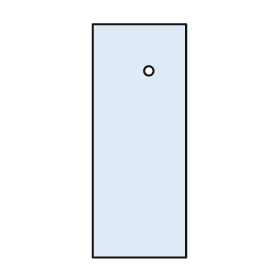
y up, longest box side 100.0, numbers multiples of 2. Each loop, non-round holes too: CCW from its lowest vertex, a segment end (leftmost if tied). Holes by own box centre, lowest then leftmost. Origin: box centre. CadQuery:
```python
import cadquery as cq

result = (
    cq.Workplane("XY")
    .moveTo(-20.0, -50.0)
    .lineTo(20.0, -50.0)
    .lineTo(20.0, 50.0)
    .lineTo(-20.0, 50.0)
    .close()
    .moveTo(4.0, 30.0)
    .circle(2.0)
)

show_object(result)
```